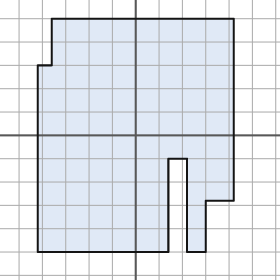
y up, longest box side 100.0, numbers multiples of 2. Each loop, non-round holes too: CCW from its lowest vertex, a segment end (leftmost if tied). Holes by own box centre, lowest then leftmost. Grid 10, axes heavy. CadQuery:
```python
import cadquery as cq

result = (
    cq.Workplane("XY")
    .moveTo(-42.0, -50.0)
    .lineTo(14.0, -50.0)
    .lineTo(14.0, -10.0)
    .lineTo(22.0, -10.0)
    .lineTo(22.0, -50.0)
    .lineTo(30.0, -50.0)
    .lineTo(30.0, -28.0)
    .lineTo(42.0, -28.0)
    .lineTo(42.0, 50.0)
    .lineTo(-36.0, 50.0)
    .lineTo(-36.0, 30.0)
    .lineTo(-42.0, 30.0)
    .close()
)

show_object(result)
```